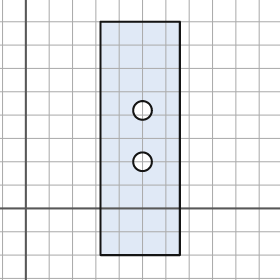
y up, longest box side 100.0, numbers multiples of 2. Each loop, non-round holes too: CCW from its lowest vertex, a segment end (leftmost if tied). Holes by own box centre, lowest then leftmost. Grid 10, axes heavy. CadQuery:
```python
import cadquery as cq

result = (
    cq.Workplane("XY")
    .moveTo(32.0, -20.0)
    .lineTo(66.0, -20.0)
    .lineTo(66.0, 80.0)
    .lineTo(32.0, 80.0)
    .close()
    .moveTo(50.0, 20.0)
    .circle(4.0)
    .moveTo(50.0, 42.0)
    .circle(4.0)
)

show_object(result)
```